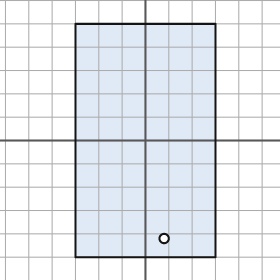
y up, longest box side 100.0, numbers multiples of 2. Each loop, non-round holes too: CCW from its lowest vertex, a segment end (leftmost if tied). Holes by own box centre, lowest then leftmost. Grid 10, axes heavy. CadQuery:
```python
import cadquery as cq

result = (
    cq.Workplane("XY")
    .moveTo(-30.0, -50.0)
    .lineTo(30.0, -50.0)
    .lineTo(30.0, 50.0)
    .lineTo(-30.0, 50.0)
    .close()
    .moveTo(8.0, -42.0)
    .circle(2.0)
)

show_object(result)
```